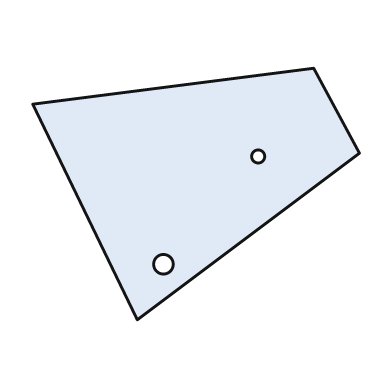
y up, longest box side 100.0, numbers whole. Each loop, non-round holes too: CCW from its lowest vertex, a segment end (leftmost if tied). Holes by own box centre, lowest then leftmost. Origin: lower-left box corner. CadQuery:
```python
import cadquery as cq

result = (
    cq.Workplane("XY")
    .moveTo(32.0, 0.0)
    .lineTo(100.0, 51.0)
    .lineTo(86.0, 77.0)
    .lineTo(0.0, 66.0)
    .close()
    .moveTo(40.0, 17.0)
    .circle(3.0)
    .moveTo(69.0, 50.0)
    .circle(2.0)
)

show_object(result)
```